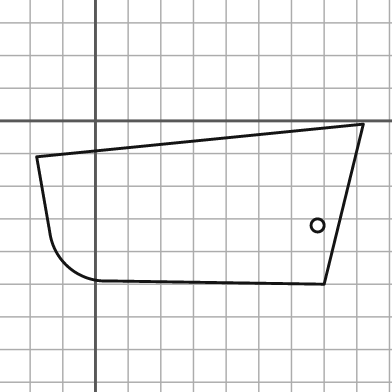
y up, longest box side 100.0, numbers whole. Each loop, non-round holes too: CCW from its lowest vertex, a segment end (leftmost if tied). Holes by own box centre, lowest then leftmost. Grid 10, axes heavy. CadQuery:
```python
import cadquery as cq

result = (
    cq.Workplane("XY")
    .moveTo(70.0, -50.0)
    .lineTo(82.0, -1.0)
    .lineTo(-18.0, -11.0)
    .lineTo(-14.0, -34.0)
    .threePointArc((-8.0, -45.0), (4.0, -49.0))
    .close()
    .moveTo(68.0, -32.0)
    .circle(2.0)
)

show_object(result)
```